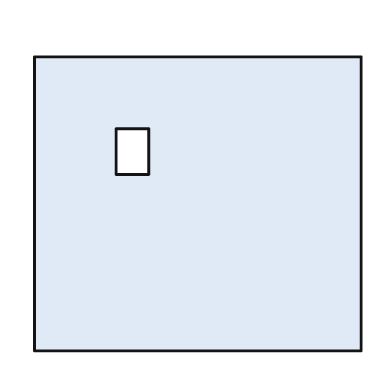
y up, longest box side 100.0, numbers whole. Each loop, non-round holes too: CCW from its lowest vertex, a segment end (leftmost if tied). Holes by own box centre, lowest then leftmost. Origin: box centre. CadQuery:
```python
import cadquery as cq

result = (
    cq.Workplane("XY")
    .moveTo(-50.0, -45.0)
    .lineTo(50.0, -45.0)
    .lineTo(50.0, 45.0)
    .lineTo(-50.0, 45.0)
    .close()
    .moveTo(-25.0, 9.0)
    .lineTo(-15.0, 9.0)
    .lineTo(-15.0, 23.0)
    .lineTo(-25.0, 23.0)
    .close()
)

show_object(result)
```